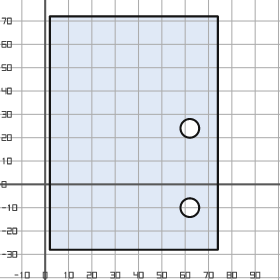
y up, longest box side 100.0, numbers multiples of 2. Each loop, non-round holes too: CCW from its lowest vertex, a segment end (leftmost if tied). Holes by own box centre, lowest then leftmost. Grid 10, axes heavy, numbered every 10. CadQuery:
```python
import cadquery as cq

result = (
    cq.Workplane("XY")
    .moveTo(2.0, -28.0)
    .lineTo(74.0, -28.0)
    .lineTo(74.0, 72.0)
    .lineTo(2.0, 72.0)
    .close()
    .moveTo(62.0, -10.0)
    .circle(4.0)
    .moveTo(62.0, 24.0)
    .circle(4.0)
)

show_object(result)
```